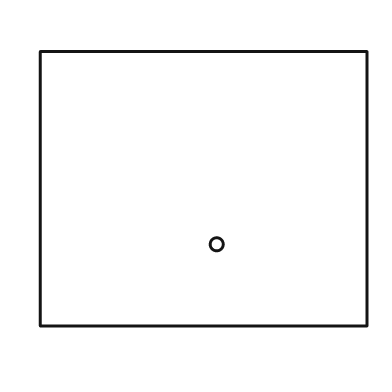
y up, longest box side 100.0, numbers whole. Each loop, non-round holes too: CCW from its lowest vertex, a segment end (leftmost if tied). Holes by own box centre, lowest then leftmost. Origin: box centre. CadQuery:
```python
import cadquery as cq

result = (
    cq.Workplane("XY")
    .moveTo(-50.0, -42.0)
    .lineTo(50.0, -42.0)
    .lineTo(50.0, 42.0)
    .lineTo(-50.0, 42.0)
    .close()
    .moveTo(4.0, -17.0)
    .circle(2.0)
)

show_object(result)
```